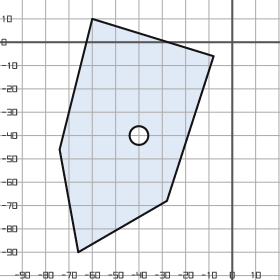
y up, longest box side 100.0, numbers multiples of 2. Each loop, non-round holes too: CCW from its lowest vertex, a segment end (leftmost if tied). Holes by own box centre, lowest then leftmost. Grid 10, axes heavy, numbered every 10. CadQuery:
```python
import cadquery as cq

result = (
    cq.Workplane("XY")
    .moveTo(-66.0, -90.0)
    .lineTo(-28.0, -68.0)
    .lineTo(-8.0, -6.0)
    .lineTo(-60.0, 10.0)
    .lineTo(-74.0, -46.0)
    .close()
    .moveTo(-40.0, -40.0)
    .circle(4.0)
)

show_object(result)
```